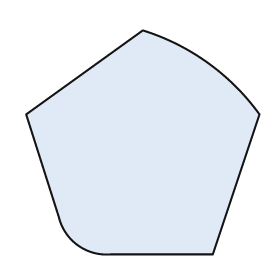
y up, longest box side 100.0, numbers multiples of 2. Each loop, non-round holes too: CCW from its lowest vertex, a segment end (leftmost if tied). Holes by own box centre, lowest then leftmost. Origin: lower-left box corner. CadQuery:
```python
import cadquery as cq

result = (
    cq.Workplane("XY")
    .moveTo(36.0, 0.0)
    .lineTo(80.0, 0.0)
    .lineTo(100.0, 60.0)
    .threePointArc((78.0, 82.0), (50.0, 96.0))
    .lineTo(0.0, 60.0)
    .lineTo(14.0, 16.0)
    .threePointArc((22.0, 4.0), (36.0, 0.0))
    .close()
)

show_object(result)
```